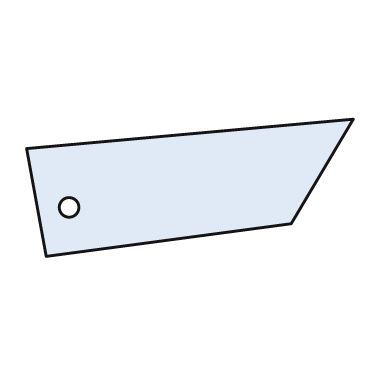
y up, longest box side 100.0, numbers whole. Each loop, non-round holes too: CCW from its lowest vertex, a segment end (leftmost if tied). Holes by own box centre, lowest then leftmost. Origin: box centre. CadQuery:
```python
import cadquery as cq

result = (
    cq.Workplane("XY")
    .moveTo(-44.0, -21.0)
    .lineTo(31.0, -11.0)
    .lineTo(50.0, 21.0)
    .lineTo(-50.0, 12.0)
    .close()
    .moveTo(-37.0, -6.0)
    .circle(3.0)
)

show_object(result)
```